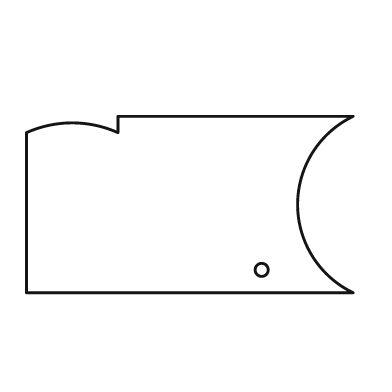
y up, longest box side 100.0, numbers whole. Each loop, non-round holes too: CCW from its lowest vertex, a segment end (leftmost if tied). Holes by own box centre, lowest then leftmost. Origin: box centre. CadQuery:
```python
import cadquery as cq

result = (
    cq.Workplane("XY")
    .moveTo(-50.0, -27.0)
    .lineTo(50.0, -27.0)
    .threePointArc((33.0, 0.0), (50.0, 27.0))
    .lineTo(-22.0, 27.0)
    .lineTo(-22.0, 22.0)
    .threePointArc((-36.0, 25.0), (-50.0, 22.0))
    .close()
    .moveTo(22.0, -20.0)
    .circle(2.0)
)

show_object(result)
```